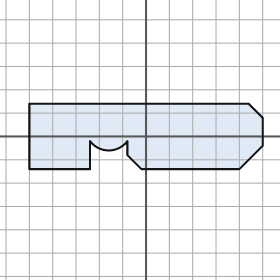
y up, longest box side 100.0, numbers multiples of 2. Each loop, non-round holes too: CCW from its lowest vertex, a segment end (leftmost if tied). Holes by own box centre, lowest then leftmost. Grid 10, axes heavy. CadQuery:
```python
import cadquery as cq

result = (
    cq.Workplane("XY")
    .moveTo(-50.0, -14.0)
    .lineTo(-24.0, -14.0)
    .lineTo(-24.0, -2.0)
    .threePointArc((-16.0, -6.0), (-8.0, -2.0))
    .lineTo(-8.0, -8.0)
    .lineTo(-2.0, -14.0)
    .lineTo(40.0, -14.0)
    .lineTo(50.0, -4.0)
    .lineTo(50.0, 8.0)
    .lineTo(44.0, 14.0)
    .lineTo(-50.0, 14.0)
    .close()
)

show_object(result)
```